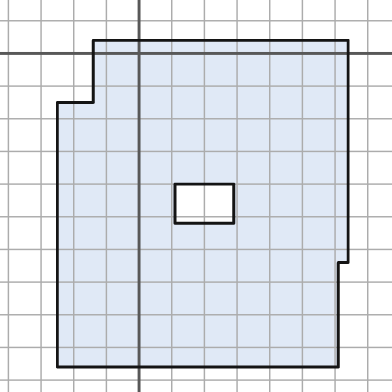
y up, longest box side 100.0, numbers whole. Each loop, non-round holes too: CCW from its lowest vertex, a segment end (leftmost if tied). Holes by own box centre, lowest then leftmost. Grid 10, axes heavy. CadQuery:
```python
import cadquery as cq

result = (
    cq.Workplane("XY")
    .moveTo(-25.0, -96.0)
    .lineTo(61.0, -96.0)
    .lineTo(61.0, -64.0)
    .lineTo(64.0, -64.0)
    .lineTo(64.0, 4.0)
    .lineTo(-14.0, 4.0)
    .lineTo(-14.0, -15.0)
    .lineTo(-25.0, -15.0)
    .close()
    .moveTo(11.0, -52.0)
    .lineTo(29.0, -52.0)
    .lineTo(29.0, -40.0)
    .lineTo(11.0, -40.0)
    .close()
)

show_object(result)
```